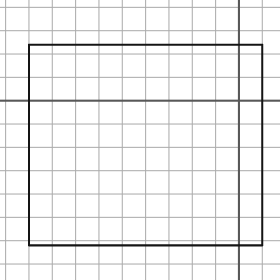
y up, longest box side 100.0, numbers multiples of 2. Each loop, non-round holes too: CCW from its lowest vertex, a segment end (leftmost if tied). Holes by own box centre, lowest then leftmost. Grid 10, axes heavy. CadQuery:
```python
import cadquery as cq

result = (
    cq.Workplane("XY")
    .moveTo(-90.0, -62.0)
    .lineTo(10.0, -62.0)
    .lineTo(10.0, 24.0)
    .lineTo(-90.0, 24.0)
    .close()
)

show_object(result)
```